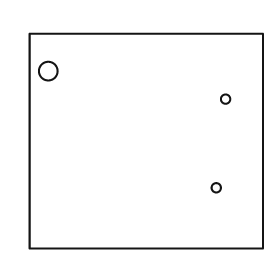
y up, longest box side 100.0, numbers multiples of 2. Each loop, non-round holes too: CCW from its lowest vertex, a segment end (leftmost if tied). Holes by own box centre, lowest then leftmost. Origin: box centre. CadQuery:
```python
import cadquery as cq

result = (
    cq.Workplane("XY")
    .moveTo(-50.0, -46.0)
    .lineTo(50.0, -46.0)
    .lineTo(50.0, 46.0)
    .lineTo(-50.0, 46.0)
    .close()
    .moveTo(30.0, -20.0)
    .circle(2.0)
    .moveTo(34.0, 18.0)
    .circle(2.0)
    .moveTo(-42.0, 30.0)
    .circle(4.0)
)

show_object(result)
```